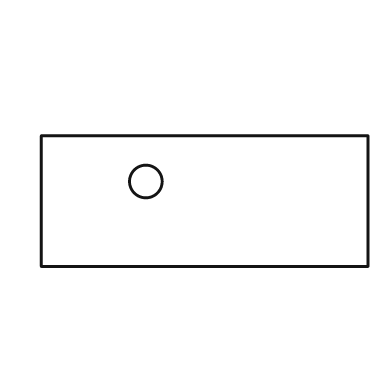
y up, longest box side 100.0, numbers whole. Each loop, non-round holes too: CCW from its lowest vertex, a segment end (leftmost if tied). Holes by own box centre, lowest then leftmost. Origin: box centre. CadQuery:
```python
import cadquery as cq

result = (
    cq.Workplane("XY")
    .moveTo(-50.0, -20.0)
    .lineTo(50.0, -20.0)
    .lineTo(50.0, 20.0)
    .lineTo(-50.0, 20.0)
    .close()
    .moveTo(-18.0, 6.0)
    .circle(5.0)
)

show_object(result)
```